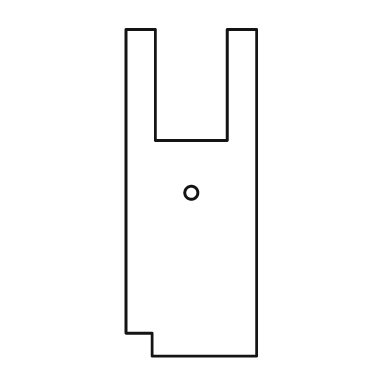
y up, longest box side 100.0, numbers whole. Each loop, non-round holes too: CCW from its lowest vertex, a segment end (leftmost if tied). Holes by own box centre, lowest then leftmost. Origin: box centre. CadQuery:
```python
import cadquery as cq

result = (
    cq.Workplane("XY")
    .moveTo(-12.0, -50.0)
    .lineTo(20.0, -50.0)
    .lineTo(20.0, 50.0)
    .lineTo(11.0, 50.0)
    .lineTo(11.0, 16.0)
    .lineTo(-11.0, 16.0)
    .lineTo(-11.0, 50.0)
    .lineTo(-20.0, 50.0)
    .lineTo(-20.0, -43.0)
    .lineTo(-12.0, -43.0)
    .close()
    .moveTo(0.0, 0.0)
    .circle(2.0)
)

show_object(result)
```